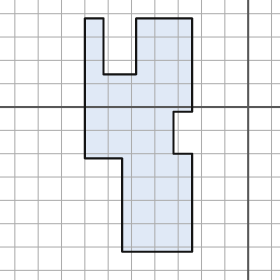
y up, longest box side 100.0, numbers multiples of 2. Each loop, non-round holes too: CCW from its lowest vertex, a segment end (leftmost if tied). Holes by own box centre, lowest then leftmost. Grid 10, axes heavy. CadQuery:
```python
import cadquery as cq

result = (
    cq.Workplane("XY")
    .moveTo(-54.0, -62.0)
    .lineTo(-24.0, -62.0)
    .lineTo(-24.0, -20.0)
    .lineTo(-32.0, -20.0)
    .lineTo(-32.0, -2.0)
    .lineTo(-24.0, -2.0)
    .lineTo(-24.0, 38.0)
    .lineTo(-48.0, 38.0)
    .lineTo(-48.0, 14.0)
    .lineTo(-62.0, 14.0)
    .lineTo(-62.0, 38.0)
    .lineTo(-70.0, 38.0)
    .lineTo(-70.0, -22.0)
    .lineTo(-54.0, -22.0)
    .close()
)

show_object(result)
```